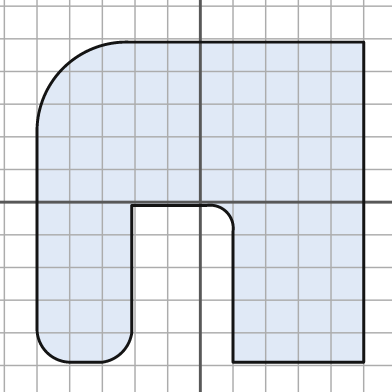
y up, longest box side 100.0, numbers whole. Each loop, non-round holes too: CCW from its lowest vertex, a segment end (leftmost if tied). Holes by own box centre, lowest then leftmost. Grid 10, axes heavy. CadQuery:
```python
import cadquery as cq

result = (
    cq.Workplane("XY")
    .moveTo(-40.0, -49.0)
    .lineTo(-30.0, -49.0)
    .threePointArc((-24.0, -46.0), (-21.0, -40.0))
    .lineTo(-21.0, -1.0)
    .lineTo(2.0, -1.0)
    .threePointArc((8.0, -3.0), (10.0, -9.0))
    .lineTo(10.0, -49.0)
    .lineTo(50.0, -49.0)
    .lineTo(50.0, 49.0)
    .lineTo(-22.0, 49.0)
    .threePointArc((-42.0, 41.0), (-50.0, 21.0))
    .lineTo(-50.0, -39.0)
    .threePointArc((-47.0, -46.0), (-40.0, -49.0))
    .close()
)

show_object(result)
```